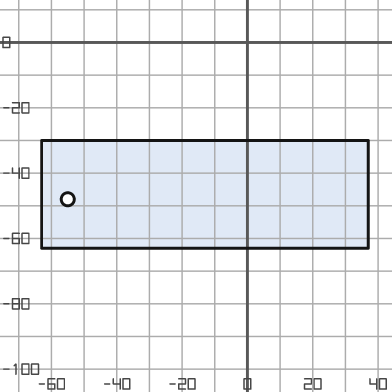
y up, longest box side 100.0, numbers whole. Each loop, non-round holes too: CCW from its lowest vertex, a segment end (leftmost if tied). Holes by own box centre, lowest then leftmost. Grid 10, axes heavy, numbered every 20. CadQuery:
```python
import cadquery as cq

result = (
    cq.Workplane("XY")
    .moveTo(-63.0, -63.0)
    .lineTo(37.0, -63.0)
    .lineTo(37.0, -30.0)
    .lineTo(-63.0, -30.0)
    .close()
    .moveTo(-55.0, -48.0)
    .circle(2.0)
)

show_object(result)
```